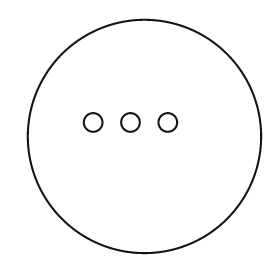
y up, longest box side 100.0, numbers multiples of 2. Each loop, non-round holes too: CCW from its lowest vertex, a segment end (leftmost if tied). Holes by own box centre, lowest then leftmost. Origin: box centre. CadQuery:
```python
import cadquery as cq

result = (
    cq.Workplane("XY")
    .moveTo(0.0, 0.0)
    .circle(50.0)
    .moveTo(-22.0, 6.0)
    .circle(4.0)
    .moveTo(-6.0, 6.0)
    .circle(4.0)
    .moveTo(10.0, 6.0)
    .circle(4.0)
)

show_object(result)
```